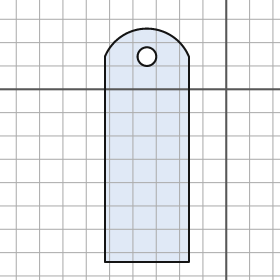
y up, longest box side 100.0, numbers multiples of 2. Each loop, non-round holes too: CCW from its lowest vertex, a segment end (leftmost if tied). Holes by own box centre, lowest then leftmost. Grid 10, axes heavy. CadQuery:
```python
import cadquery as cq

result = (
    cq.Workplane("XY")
    .moveTo(-52.0, -74.0)
    .lineTo(-16.0, -74.0)
    .lineTo(-16.0, 14.0)
    .threePointArc((-34.0, 26.0), (-52.0, 14.0))
    .close()
    .moveTo(-34.0, 14.0)
    .circle(4.0)
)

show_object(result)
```